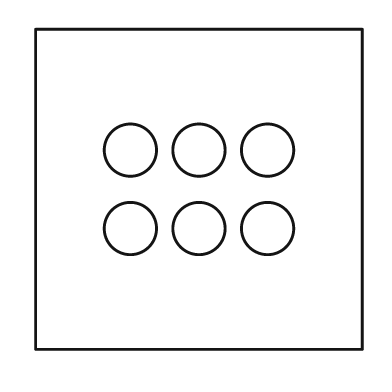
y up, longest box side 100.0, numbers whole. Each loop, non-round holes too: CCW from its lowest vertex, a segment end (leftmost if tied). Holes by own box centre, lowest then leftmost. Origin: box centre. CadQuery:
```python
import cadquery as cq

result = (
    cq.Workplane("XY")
    .moveTo(-50.0, -49.0)
    .lineTo(50.0, -49.0)
    .lineTo(50.0, 49.0)
    .lineTo(-50.0, 49.0)
    .close()
    .moveTo(-21.0, -12.0)
    .circle(8.0)
    .moveTo(0.0, -12.0)
    .circle(8.0)
    .moveTo(21.0, -12.0)
    .circle(8.0)
    .moveTo(-21.0, 12.0)
    .circle(8.0)
    .moveTo(0.0, 12.0)
    .circle(8.0)
    .moveTo(21.0, 12.0)
    .circle(8.0)
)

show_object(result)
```